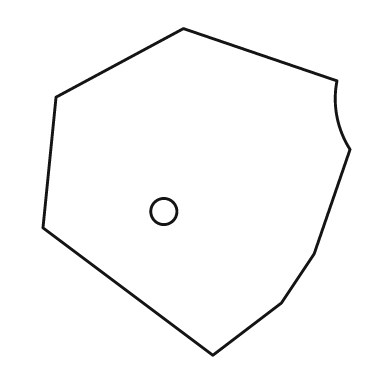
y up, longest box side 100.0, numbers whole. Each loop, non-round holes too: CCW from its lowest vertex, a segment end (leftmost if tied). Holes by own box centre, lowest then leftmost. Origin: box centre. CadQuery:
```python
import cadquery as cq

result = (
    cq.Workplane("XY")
    .moveTo(5.0, -50.0)
    .lineTo(26.0, -34.0)
    .lineTo(36.0, -19.0)
    .lineTo(47.0, 13.0)
    .threePointArc((43.0, 23.0), (43.0, 34.0))
    .lineTo(-4.0, 50.0)
    .lineTo(-43.0, 29.0)
    .lineTo(-47.0, -11.0)
    .close()
    .moveTo(-10.0, -6.0)
    .circle(4.0)
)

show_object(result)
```